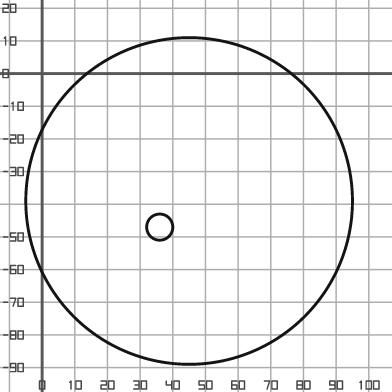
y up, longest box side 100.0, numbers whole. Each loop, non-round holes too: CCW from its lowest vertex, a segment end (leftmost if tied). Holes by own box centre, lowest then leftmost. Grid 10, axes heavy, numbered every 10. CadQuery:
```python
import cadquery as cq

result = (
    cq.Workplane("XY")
    .moveTo(45.0, -39.0)
    .circle(50.0)
    .moveTo(36.0, -47.0)
    .circle(4.0)
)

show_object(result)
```